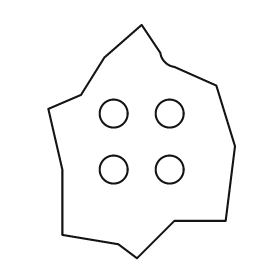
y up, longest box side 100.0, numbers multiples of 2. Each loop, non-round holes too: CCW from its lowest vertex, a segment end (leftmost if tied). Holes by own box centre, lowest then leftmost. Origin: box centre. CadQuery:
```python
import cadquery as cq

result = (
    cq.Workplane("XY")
    .moveTo(-2.0, -50.0)
    .lineTo(14.0, -34.0)
    .lineTo(36.0, -34.0)
    .lineTo(40.0, -2.0)
    .lineTo(32.0, 24.0)
    .lineTo(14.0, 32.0)
    .threePointArc((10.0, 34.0), (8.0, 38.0))
    .lineTo(0.0, 50.0)
    .lineTo(-16.0, 36.0)
    .lineTo(-26.0, 20.0)
    .lineTo(-40.0, 14.0)
    .lineTo(-34.0, -12.0)
    .lineTo(-34.0, -40.0)
    .lineTo(-10.0, -44.0)
    .close()
    .moveTo(-12.0, -12.0)
    .circle(6.0)
    .moveTo(12.0, -12.0)
    .circle(6.0)
    .moveTo(-12.0, 12.0)
    .circle(6.0)
    .moveTo(12.0, 12.0)
    .circle(6.0)
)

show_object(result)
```